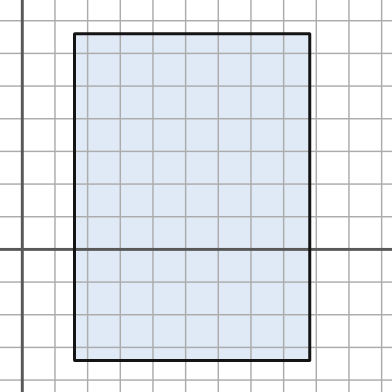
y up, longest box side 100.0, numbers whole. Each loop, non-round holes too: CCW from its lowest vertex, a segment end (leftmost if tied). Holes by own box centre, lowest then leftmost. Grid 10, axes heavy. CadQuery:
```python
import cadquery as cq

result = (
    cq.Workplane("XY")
    .moveTo(16.0, -34.0)
    .lineTo(88.0, -34.0)
    .lineTo(88.0, 66.0)
    .lineTo(16.0, 66.0)
    .close()
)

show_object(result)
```